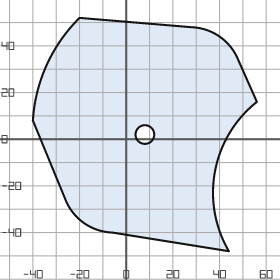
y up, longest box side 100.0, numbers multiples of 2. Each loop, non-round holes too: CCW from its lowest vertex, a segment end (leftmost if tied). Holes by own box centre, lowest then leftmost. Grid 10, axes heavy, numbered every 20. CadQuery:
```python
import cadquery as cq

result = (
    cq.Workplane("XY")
    .moveTo(44.0, -48.0)
    .threePointArc((38.0, -14.0), (56.0, 16.0))
    .lineTo(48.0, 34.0)
    .threePointArc((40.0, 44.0), (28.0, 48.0))
    .lineTo(-20.0, 52.0)
    .threePointArc((-34.0, 32.0), (-40.0, 8.0))
    .lineTo(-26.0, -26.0)
    .threePointArc((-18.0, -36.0), (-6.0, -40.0))
    .close()
    .moveTo(8.0, 2.0)
    .circle(4.0)
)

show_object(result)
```